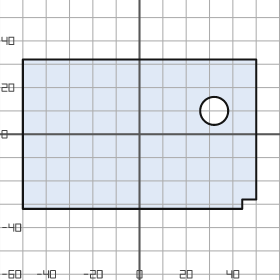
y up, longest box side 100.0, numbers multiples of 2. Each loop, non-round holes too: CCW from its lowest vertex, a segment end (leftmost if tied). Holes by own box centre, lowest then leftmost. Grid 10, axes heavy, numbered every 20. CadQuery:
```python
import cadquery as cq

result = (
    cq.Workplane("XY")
    .moveTo(-50.0, -32.0)
    .lineTo(44.0, -32.0)
    .lineTo(44.0, -28.0)
    .lineTo(50.0, -28.0)
    .lineTo(50.0, 32.0)
    .lineTo(-50.0, 32.0)
    .close()
    .moveTo(32.0, 10.0)
    .circle(6.0)
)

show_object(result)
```